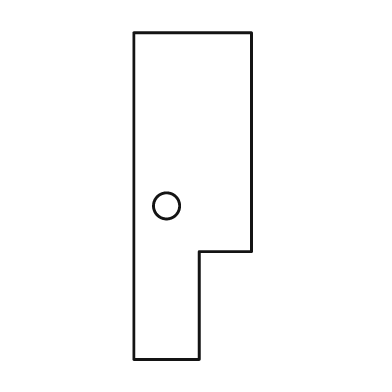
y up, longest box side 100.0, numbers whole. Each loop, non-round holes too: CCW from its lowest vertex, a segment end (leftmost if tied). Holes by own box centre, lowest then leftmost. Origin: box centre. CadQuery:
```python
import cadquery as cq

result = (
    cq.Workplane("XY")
    .moveTo(-18.0, -50.0)
    .lineTo(2.0, -50.0)
    .lineTo(2.0, -17.0)
    .lineTo(18.0, -17.0)
    .lineTo(18.0, 50.0)
    .lineTo(-18.0, 50.0)
    .close()
    .moveTo(-8.0, -3.0)
    .circle(4.0)
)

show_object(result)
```